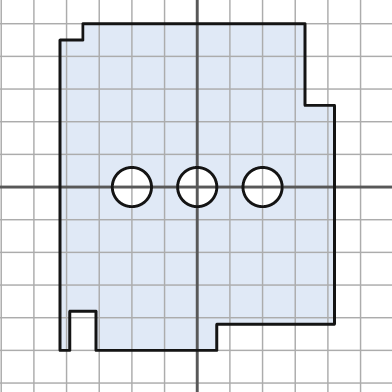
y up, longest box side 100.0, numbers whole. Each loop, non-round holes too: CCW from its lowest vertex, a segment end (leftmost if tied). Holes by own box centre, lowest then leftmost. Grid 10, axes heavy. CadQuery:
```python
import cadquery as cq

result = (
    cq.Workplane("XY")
    .moveTo(-42.0, -50.0)
    .lineTo(-39.0, -50.0)
    .lineTo(-39.0, -38.0)
    .lineTo(-31.0, -38.0)
    .lineTo(-31.0, -50.0)
    .lineTo(6.0, -50.0)
    .lineTo(6.0, -42.0)
    .lineTo(42.0, -42.0)
    .lineTo(42.0, 25.0)
    .lineTo(33.0, 25.0)
    .lineTo(33.0, 50.0)
    .lineTo(-35.0, 50.0)
    .lineTo(-35.0, 45.0)
    .lineTo(-42.0, 45.0)
    .close()
    .moveTo(-20.0, 0.0)
    .circle(6.0)
    .moveTo(0.0, 0.0)
    .circle(6.0)
    .moveTo(20.0, 0.0)
    .circle(6.0)
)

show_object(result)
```